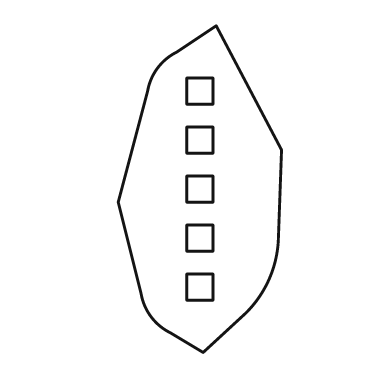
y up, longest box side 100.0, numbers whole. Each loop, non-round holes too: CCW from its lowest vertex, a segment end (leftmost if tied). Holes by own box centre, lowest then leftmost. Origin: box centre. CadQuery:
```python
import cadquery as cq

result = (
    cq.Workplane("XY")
    .moveTo(1.0, -50.0)
    .lineTo(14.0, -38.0)
    .threePointArc((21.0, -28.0), (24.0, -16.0))
    .lineTo(25.0, 12.0)
    .lineTo(5.0, 50.0)
    .lineTo(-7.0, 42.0)
    .threePointArc((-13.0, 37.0), (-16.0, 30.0))
    .lineTo(-25.0, -4.0)
    .lineTo(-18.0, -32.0)
    .threePointArc((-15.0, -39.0), (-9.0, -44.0))
    .close()
    .moveTo(-4.0, -34.0)
    .lineTo(4.0, -34.0)
    .lineTo(4.0, -26.0)
    .lineTo(-4.0, -26.0)
    .close()
    .moveTo(-4.0, -19.0)
    .lineTo(4.0, -19.0)
    .lineTo(4.0, -11.0)
    .lineTo(-4.0, -11.0)
    .close()
    .moveTo(-4.0, -4.0)
    .lineTo(4.0, -4.0)
    .lineTo(4.0, 4.0)
    .lineTo(-4.0, 4.0)
    .close()
    .moveTo(-4.0, 11.0)
    .lineTo(4.0, 11.0)
    .lineTo(4.0, 19.0)
    .lineTo(-4.0, 19.0)
    .close()
    .moveTo(-4.0, 26.0)
    .lineTo(4.0, 26.0)
    .lineTo(4.0, 34.0)
    .lineTo(-4.0, 34.0)
    .close()
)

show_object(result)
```